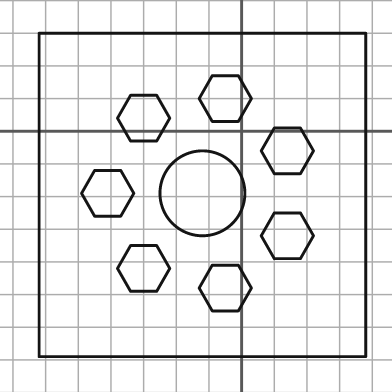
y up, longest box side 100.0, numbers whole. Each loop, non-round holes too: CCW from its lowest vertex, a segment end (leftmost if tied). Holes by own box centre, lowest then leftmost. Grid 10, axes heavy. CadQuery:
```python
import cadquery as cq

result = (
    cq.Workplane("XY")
    .moveTo(-62.0, -69.0)
    .lineTo(38.0, -69.0)
    .lineTo(38.0, 30.0)
    .lineTo(-62.0, 30.0)
    .close()
    .moveTo(-9.0, -55.0)
    .lineTo(-1.0, -55.0)
    .lineTo(3.0, -48.0)
    .lineTo(-1.0, -41.0)
    .lineTo(-9.0, -41.0)
    .lineTo(-13.0, -48.0)
    .close()
    .moveTo(-34.0, -49.0)
    .lineTo(-26.0, -49.0)
    .lineTo(-22.0, -42.0)
    .lineTo(-26.0, -35.0)
    .lineTo(-34.0, -35.0)
    .lineTo(-38.0, -42.0)
    .close()
    .moveTo(10.0, -39.0)
    .lineTo(18.0, -39.0)
    .lineTo(22.0, -32.0)
    .lineTo(18.0, -25.0)
    .lineTo(10.0, -25.0)
    .lineTo(6.0, -32.0)
    .close()
    .moveTo(-45.0, -26.0)
    .lineTo(-37.0, -26.0)
    .lineTo(-33.0, -19.0)
    .lineTo(-37.0, -12.0)
    .lineTo(-45.0, -12.0)
    .lineTo(-49.0, -19.0)
    .close()
    .moveTo(-12.0, -19.0)
    .circle(13.0)
    .moveTo(10.0, -13.0)
    .lineTo(18.0, -13.0)
    .lineTo(22.0, -6.0)
    .lineTo(18.0, 1.0)
    .lineTo(10.0, 1.0)
    .lineTo(6.0, -6.0)
    .close()
    .moveTo(-34.0, -3.0)
    .lineTo(-26.0, -3.0)
    .lineTo(-22.0, 4.0)
    .lineTo(-26.0, 11.0)
    .lineTo(-34.0, 11.0)
    .lineTo(-38.0, 4.0)
    .close()
    .moveTo(-9.0, 3.0)
    .lineTo(-1.0, 3.0)
    .lineTo(3.0, 10.0)
    .lineTo(-1.0, 17.0)
    .lineTo(-9.0, 17.0)
    .lineTo(-13.0, 10.0)
    .close()
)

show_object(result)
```